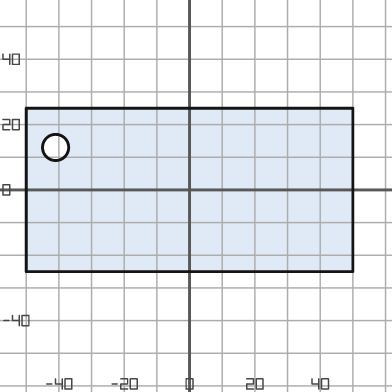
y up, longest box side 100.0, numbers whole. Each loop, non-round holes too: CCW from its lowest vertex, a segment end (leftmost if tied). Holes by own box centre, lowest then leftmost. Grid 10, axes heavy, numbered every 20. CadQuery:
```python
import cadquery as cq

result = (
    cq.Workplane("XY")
    .moveTo(-50.0, -25.0)
    .lineTo(50.0, -25.0)
    .lineTo(50.0, 25.0)
    .lineTo(-50.0, 25.0)
    .close()
    .moveTo(-41.0, 13.0)
    .circle(4.0)
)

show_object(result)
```